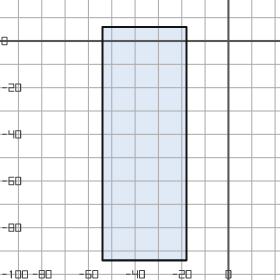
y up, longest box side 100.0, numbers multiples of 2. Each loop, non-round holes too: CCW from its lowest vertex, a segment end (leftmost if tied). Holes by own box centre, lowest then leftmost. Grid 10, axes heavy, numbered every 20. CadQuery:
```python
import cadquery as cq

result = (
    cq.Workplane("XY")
    .moveTo(-54.0, -94.0)
    .lineTo(-18.0, -94.0)
    .lineTo(-18.0, 6.0)
    .lineTo(-54.0, 6.0)
    .close()
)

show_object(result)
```